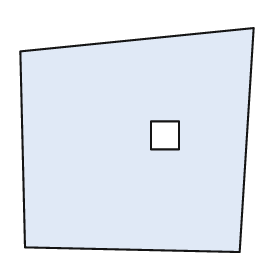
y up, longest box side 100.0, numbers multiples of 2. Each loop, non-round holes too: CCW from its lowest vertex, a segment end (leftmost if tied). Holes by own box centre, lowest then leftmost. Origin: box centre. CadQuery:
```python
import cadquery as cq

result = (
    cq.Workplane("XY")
    .moveTo(44.0, -48.0)
    .lineTo(50.0, 48.0)
    .lineTo(-50.0, 38.0)
    .lineTo(-48.0, -46.0)
    .close()
    .moveTo(6.0, -4.0)
    .lineTo(18.0, -4.0)
    .lineTo(18.0, 8.0)
    .lineTo(6.0, 8.0)
    .close()
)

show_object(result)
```